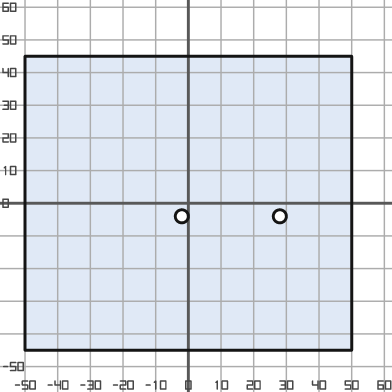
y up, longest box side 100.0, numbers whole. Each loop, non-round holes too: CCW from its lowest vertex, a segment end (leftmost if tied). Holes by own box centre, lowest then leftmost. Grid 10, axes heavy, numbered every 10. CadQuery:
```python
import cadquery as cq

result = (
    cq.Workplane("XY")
    .moveTo(-50.0, -45.0)
    .lineTo(50.0, -45.0)
    .lineTo(50.0, 45.0)
    .lineTo(-50.0, 45.0)
    .close()
    .moveTo(-2.0, -4.0)
    .circle(2.0)
    .moveTo(28.0, -4.0)
    .circle(2.0)
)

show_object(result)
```